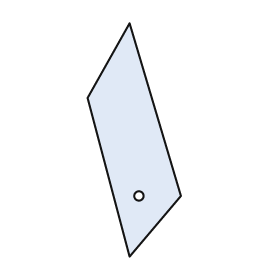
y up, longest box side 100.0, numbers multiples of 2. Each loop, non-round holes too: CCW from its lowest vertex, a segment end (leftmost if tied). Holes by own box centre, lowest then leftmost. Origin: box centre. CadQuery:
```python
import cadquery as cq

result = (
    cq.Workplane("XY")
    .moveTo(-2.0, -50.0)
    .lineTo(20.0, -24.0)
    .lineTo(-2.0, 50.0)
    .lineTo(-20.0, 18.0)
    .close()
    .moveTo(2.0, -24.0)
    .circle(2.0)
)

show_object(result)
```